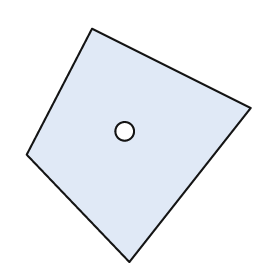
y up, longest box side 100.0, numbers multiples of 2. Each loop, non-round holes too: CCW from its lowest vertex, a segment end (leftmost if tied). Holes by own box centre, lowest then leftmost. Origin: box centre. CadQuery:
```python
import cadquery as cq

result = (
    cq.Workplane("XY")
    .moveTo(-4.0, -50.0)
    .lineTo(48.0, 16.0)
    .lineTo(-20.0, 50.0)
    .lineTo(-48.0, -4.0)
    .close()
    .moveTo(-6.0, 6.0)
    .circle(4.0)
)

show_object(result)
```